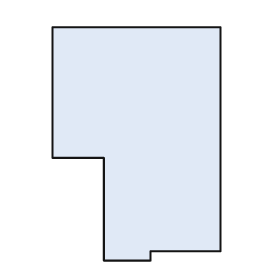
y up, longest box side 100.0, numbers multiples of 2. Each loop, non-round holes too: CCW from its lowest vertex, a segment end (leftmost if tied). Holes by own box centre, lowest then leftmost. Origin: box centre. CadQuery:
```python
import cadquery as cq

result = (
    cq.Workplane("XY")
    .moveTo(-14.0, -50.0)
    .lineTo(6.0, -50.0)
    .lineTo(6.0, -46.0)
    .lineTo(36.0, -46.0)
    .lineTo(36.0, 50.0)
    .lineTo(-36.0, 50.0)
    .lineTo(-36.0, -6.0)
    .lineTo(-14.0, -6.0)
    .close()
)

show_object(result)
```